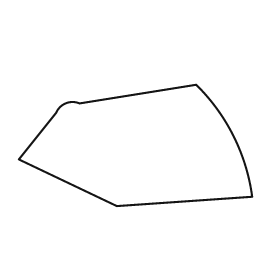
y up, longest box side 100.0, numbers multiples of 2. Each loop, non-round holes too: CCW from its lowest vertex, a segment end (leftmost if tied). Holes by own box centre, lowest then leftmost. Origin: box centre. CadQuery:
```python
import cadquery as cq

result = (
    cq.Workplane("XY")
    .moveTo(-8.0, -26.0)
    .lineTo(50.0, -22.0)
    .threePointArc((42.0, 4.0), (26.0, 26.0))
    .lineTo(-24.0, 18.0)
    .threePointArc((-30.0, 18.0), (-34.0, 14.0))
    .lineTo(-50.0, -6.0)
    .close()
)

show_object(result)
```